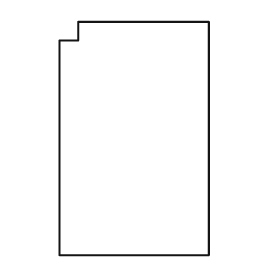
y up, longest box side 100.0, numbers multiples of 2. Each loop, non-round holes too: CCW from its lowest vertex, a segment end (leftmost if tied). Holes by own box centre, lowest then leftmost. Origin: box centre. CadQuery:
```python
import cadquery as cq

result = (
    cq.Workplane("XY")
    .moveTo(-32.0, -50.0)
    .lineTo(32.0, -50.0)
    .lineTo(32.0, 50.0)
    .lineTo(-24.0, 50.0)
    .lineTo(-24.0, 42.0)
    .lineTo(-32.0, 42.0)
    .close()
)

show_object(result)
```